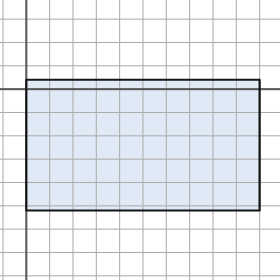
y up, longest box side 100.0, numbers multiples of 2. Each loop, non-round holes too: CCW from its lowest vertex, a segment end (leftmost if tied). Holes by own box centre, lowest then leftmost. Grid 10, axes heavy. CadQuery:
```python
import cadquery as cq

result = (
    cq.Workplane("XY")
    .moveTo(0.0, -52.0)
    .lineTo(100.0, -52.0)
    .lineTo(100.0, 4.0)
    .lineTo(0.0, 4.0)
    .close()
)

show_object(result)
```